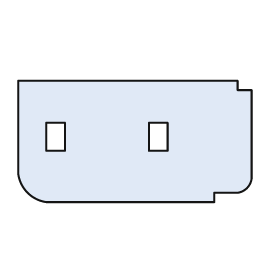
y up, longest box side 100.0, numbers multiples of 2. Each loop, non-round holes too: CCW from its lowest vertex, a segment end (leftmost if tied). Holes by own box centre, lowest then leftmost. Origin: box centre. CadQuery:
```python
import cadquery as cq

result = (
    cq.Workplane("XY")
    .moveTo(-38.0, -26.0)
    .lineTo(34.0, -26.0)
    .lineTo(34.0, -22.0)
    .lineTo(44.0, -22.0)
    .threePointArc((48.0, -20.0), (50.0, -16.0))
    .lineTo(50.0, 22.0)
    .lineTo(44.0, 22.0)
    .lineTo(44.0, 26.0)
    .lineTo(-50.0, 26.0)
    .lineTo(-50.0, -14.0)
    .threePointArc((-46.0, -22.0), (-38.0, -26.0))
    .close()
    .moveTo(-38.0, -4.0)
    .lineTo(-30.0, -4.0)
    .lineTo(-30.0, 8.0)
    .lineTo(-38.0, 8.0)
    .close()
    .moveTo(6.0, -4.0)
    .lineTo(14.0, -4.0)
    .lineTo(14.0, 8.0)
    .lineTo(6.0, 8.0)
    .close()
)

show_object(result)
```